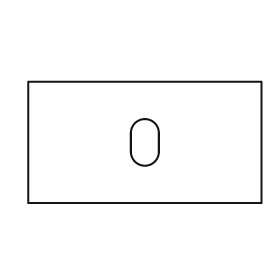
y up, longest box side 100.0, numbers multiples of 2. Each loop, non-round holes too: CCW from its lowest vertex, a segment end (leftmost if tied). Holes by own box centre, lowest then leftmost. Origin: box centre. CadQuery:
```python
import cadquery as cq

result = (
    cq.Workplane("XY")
    .moveTo(-50.0, -26.0)
    .lineTo(50.0, -26.0)
    .lineTo(50.0, 26.0)
    .lineTo(-50.0, 26.0)
    .close()
    .moveTo(-6.0, -4.0)
    .threePointArc((0.0, -10.0), (6.0, -4.0))
    .lineTo(6.0, 4.0)
    .threePointArc((0.0, 10.0), (-6.0, 4.0))
    .close()
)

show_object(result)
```